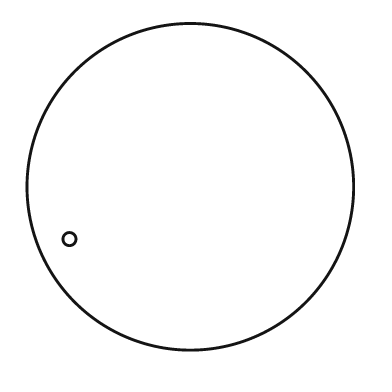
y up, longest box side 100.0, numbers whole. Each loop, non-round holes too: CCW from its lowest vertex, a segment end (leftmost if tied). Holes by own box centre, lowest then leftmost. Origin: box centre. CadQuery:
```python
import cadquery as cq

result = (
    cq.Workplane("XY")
    .moveTo(0.0, 0.0)
    .circle(50.0)
    .moveTo(-37.0, -16.0)
    .circle(2.0)
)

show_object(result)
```